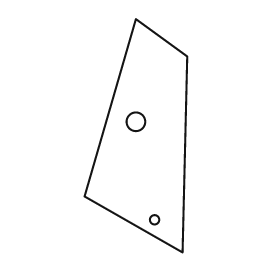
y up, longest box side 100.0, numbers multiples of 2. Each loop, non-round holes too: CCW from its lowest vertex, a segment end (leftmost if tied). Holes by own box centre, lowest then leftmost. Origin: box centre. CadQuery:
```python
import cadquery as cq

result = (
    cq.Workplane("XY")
    .moveTo(20.0, -50.0)
    .lineTo(22.0, 34.0)
    .lineTo(0.0, 50.0)
    .lineTo(-22.0, -26.0)
    .close()
    .moveTo(8.0, -36.0)
    .circle(2.0)
    .moveTo(0.0, 6.0)
    .circle(4.0)
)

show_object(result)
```